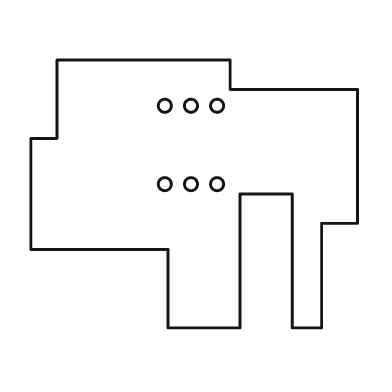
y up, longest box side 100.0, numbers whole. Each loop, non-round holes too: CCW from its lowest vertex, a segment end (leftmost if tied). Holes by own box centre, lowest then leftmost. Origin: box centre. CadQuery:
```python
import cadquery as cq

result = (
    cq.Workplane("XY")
    .moveTo(-8.0, -41.0)
    .lineTo(14.0, -41.0)
    .lineTo(14.0, 0.0)
    .lineTo(30.0, 0.0)
    .lineTo(30.0, -41.0)
    .lineTo(39.0, -41.0)
    .lineTo(39.0, -9.0)
    .lineTo(50.0, -9.0)
    .lineTo(50.0, 32.0)
    .lineTo(11.0, 32.0)
    .lineTo(11.0, 41.0)
    .lineTo(-42.0, 41.0)
    .lineTo(-42.0, 17.0)
    .lineTo(-50.0, 17.0)
    .lineTo(-50.0, -17.0)
    .lineTo(-8.0, -17.0)
    .close()
    .moveTo(-9.0, 3.0)
    .circle(2.0)
    .moveTo(-1.0, 3.0)
    .circle(2.0)
    .moveTo(7.0, 3.0)
    .circle(2.0)
    .moveTo(-9.0, 27.0)
    .circle(2.0)
    .moveTo(-1.0, 27.0)
    .circle(2.0)
    .moveTo(7.0, 27.0)
    .circle(2.0)
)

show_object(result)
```